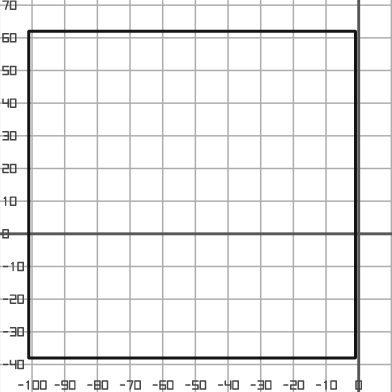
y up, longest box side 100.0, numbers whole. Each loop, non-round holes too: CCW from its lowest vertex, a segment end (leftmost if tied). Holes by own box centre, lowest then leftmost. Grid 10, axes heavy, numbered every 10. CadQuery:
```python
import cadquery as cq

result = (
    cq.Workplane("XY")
    .moveTo(-101.0, -38.0)
    .lineTo(-1.0, -38.0)
    .lineTo(-1.0, 62.0)
    .lineTo(-101.0, 62.0)
    .close()
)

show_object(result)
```